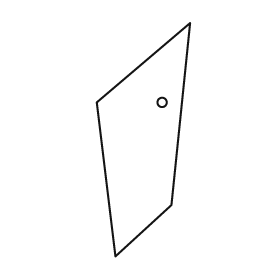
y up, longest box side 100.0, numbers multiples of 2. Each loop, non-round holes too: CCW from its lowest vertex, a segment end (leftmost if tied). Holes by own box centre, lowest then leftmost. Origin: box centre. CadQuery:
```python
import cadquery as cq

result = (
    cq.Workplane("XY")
    .moveTo(-12.0, -50.0)
    .lineTo(12.0, -28.0)
    .lineTo(20.0, 50.0)
    .lineTo(-20.0, 16.0)
    .close()
    .moveTo(8.0, 16.0)
    .circle(2.0)
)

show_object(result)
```